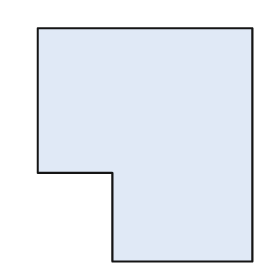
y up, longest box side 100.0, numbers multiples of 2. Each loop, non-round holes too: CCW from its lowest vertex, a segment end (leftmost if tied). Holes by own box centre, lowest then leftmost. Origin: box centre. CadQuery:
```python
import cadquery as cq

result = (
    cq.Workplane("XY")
    .moveTo(-14.0, -50.0)
    .lineTo(46.0, -50.0)
    .lineTo(46.0, 50.0)
    .lineTo(-46.0, 50.0)
    .lineTo(-46.0, -12.0)
    .lineTo(-14.0, -12.0)
    .close()
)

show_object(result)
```